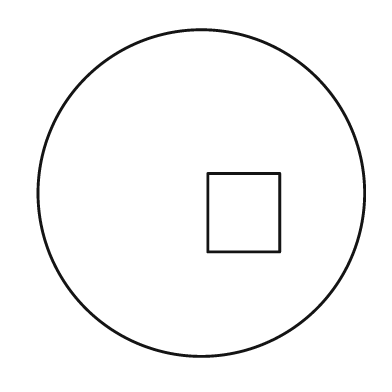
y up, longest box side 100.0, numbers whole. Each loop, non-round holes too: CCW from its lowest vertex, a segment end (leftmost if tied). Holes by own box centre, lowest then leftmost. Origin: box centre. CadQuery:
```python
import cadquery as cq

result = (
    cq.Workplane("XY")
    .moveTo(0.0, 0.0)
    .circle(50.0)
    .moveTo(2.0, -18.0)
    .lineTo(24.0, -18.0)
    .lineTo(24.0, 6.0)
    .lineTo(2.0, 6.0)
    .close()
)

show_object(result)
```